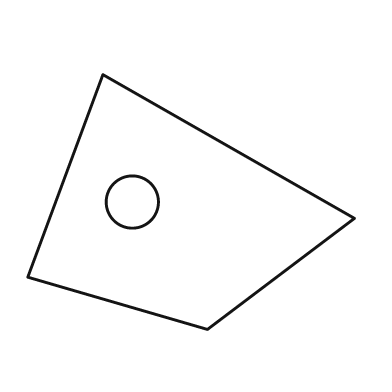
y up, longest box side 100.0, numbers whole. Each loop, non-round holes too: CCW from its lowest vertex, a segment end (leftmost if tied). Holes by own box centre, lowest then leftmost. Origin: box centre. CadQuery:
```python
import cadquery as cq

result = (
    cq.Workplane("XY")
    .moveTo(5.0, -39.0)
    .lineTo(50.0, -5.0)
    .lineTo(-27.0, 39.0)
    .lineTo(-50.0, -23.0)
    .close()
    .moveTo(-18.0, 0.0)
    .circle(8.0)
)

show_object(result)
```